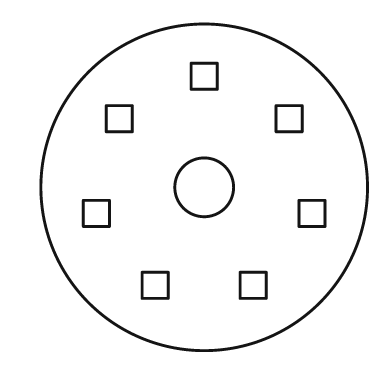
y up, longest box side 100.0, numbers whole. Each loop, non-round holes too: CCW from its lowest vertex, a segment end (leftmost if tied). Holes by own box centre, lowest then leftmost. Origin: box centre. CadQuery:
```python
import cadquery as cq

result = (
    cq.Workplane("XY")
    .moveTo(0.0, 0.0)
    .circle(50.0)
    .moveTo(-19.0, -34.0)
    .lineTo(-11.0, -34.0)
    .lineTo(-11.0, -26.0)
    .lineTo(-19.0, -26.0)
    .close()
    .moveTo(11.0, -34.0)
    .lineTo(19.0, -34.0)
    .lineTo(19.0, -26.0)
    .lineTo(11.0, -26.0)
    .close()
    .moveTo(-37.0, -12.0)
    .lineTo(-29.0, -12.0)
    .lineTo(-29.0, -4.0)
    .lineTo(-37.0, -4.0)
    .close()
    .moveTo(29.0, -12.0)
    .lineTo(37.0, -12.0)
    .lineTo(37.0, -4.0)
    .lineTo(29.0, -4.0)
    .close()
    .moveTo(0.0, 0.0)
    .circle(9.0)
    .moveTo(-30.0, 17.0)
    .lineTo(-22.0, 17.0)
    .lineTo(-22.0, 25.0)
    .lineTo(-30.0, 25.0)
    .close()
    .moveTo(22.0, 17.0)
    .lineTo(30.0, 17.0)
    .lineTo(30.0, 25.0)
    .lineTo(22.0, 25.0)
    .close()
    .moveTo(-4.0, 30.0)
    .lineTo(4.0, 30.0)
    .lineTo(4.0, 38.0)
    .lineTo(-4.0, 38.0)
    .close()
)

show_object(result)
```